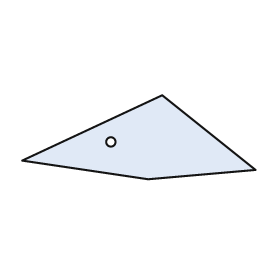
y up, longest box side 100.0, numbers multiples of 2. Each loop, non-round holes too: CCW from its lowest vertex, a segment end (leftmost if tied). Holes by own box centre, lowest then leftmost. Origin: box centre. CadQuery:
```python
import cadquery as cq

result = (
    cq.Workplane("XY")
    .moveTo(4.0, -18.0)
    .lineTo(50.0, -14.0)
    .lineTo(10.0, 18.0)
    .lineTo(-50.0, -10.0)
    .close()
    .moveTo(-12.0, -2.0)
    .circle(2.0)
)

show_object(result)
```